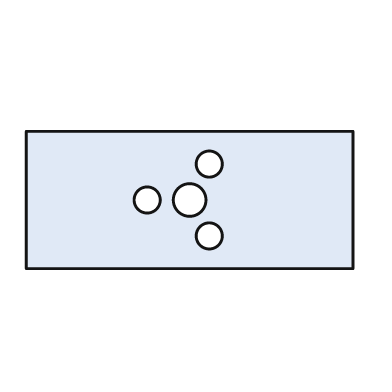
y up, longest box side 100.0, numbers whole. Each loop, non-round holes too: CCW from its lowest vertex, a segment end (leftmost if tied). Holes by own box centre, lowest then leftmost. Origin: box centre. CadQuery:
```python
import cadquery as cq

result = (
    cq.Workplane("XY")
    .moveTo(-50.0, -21.0)
    .lineTo(50.0, -21.0)
    .lineTo(50.0, 21.0)
    .lineTo(-50.0, 21.0)
    .close()
    .moveTo(6.0, -11.0)
    .circle(4.0)
    .moveTo(-13.0, 0.0)
    .circle(4.0)
    .moveTo(0.0, 0.0)
    .circle(5.0)
    .moveTo(6.0, 11.0)
    .circle(4.0)
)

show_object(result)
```